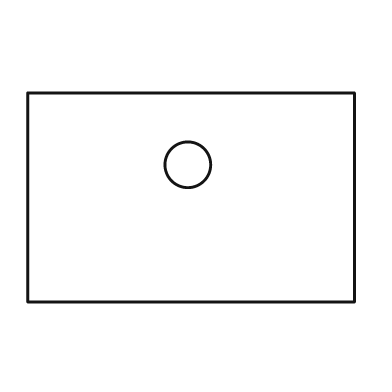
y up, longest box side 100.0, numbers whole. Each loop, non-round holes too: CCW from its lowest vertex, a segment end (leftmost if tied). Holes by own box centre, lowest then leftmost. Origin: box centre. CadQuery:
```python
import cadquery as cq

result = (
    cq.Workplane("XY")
    .moveTo(-50.0, -32.0)
    .lineTo(50.0, -32.0)
    .lineTo(50.0, 32.0)
    .lineTo(-50.0, 32.0)
    .close()
    .moveTo(-1.0, 10.0)
    .circle(7.0)
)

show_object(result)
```